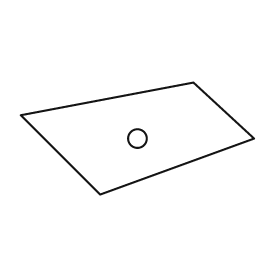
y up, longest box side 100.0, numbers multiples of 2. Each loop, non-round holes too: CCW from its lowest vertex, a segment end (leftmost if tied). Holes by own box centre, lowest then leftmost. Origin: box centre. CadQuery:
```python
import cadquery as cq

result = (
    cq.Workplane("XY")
    .moveTo(-16.0, -24.0)
    .lineTo(50.0, 0.0)
    .lineTo(24.0, 24.0)
    .lineTo(-50.0, 10.0)
    .close()
    .moveTo(0.0, 0.0)
    .circle(4.0)
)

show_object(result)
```